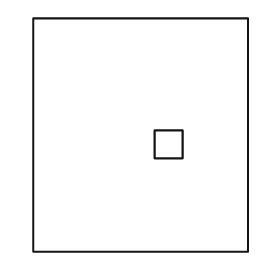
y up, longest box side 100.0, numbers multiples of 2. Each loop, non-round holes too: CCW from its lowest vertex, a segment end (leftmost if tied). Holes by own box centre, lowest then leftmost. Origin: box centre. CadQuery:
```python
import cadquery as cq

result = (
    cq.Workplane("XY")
    .moveTo(-46.0, -50.0)
    .lineTo(46.0, -50.0)
    .lineTo(46.0, 50.0)
    .lineTo(-46.0, 50.0)
    .close()
    .moveTo(6.0, -10.0)
    .lineTo(18.0, -10.0)
    .lineTo(18.0, 2.0)
    .lineTo(6.0, 2.0)
    .close()
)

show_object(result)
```